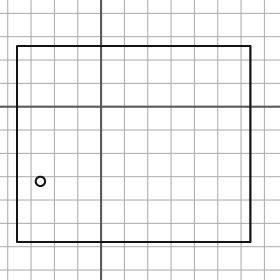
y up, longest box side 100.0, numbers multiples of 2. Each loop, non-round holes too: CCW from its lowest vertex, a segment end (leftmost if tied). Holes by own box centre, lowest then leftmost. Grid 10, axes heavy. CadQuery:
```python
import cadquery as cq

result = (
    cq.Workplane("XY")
    .moveTo(-36.0, -58.0)
    .lineTo(64.0, -58.0)
    .lineTo(64.0, 26.0)
    .lineTo(-36.0, 26.0)
    .close()
    .moveTo(-26.0, -32.0)
    .circle(2.0)
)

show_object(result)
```